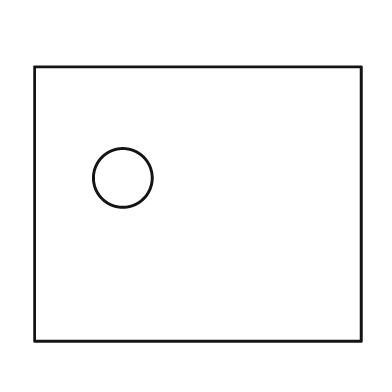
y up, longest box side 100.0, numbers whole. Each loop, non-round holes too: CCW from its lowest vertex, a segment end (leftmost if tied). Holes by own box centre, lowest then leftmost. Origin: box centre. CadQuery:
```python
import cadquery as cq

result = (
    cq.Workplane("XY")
    .moveTo(-50.0, -42.0)
    .lineTo(50.0, -42.0)
    .lineTo(50.0, 42.0)
    .lineTo(-50.0, 42.0)
    .close()
    .moveTo(-23.0, 8.0)
    .circle(9.0)
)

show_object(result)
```